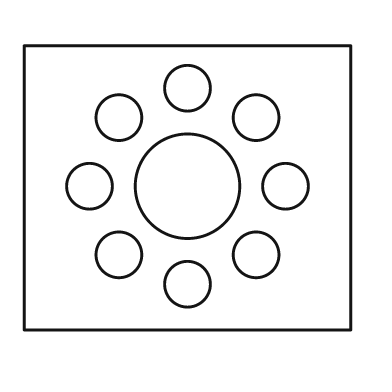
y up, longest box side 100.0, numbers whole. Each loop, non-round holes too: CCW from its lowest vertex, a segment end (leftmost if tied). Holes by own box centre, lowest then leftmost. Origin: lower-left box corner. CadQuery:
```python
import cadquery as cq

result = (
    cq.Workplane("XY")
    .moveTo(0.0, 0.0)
    .lineTo(100.0, 0.0)
    .lineTo(100.0, 87.0)
    .lineTo(0.0, 87.0)
    .close()
    .moveTo(50.0, 14.0)
    .circle(7.0)
    .moveTo(29.0, 23.0)
    .circle(7.0)
    .moveTo(71.0, 23.0)
    .circle(7.0)
    .moveTo(20.0, 44.0)
    .circle(7.0)
    .moveTo(50.0, 44.0)
    .circle(16.0)
    .moveTo(80.0, 44.0)
    .circle(7.0)
    .moveTo(29.0, 65.0)
    .circle(7.0)
    .moveTo(71.0, 65.0)
    .circle(7.0)
    .moveTo(50.0, 74.0)
    .circle(7.0)
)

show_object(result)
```